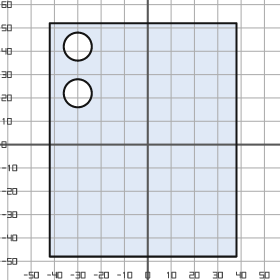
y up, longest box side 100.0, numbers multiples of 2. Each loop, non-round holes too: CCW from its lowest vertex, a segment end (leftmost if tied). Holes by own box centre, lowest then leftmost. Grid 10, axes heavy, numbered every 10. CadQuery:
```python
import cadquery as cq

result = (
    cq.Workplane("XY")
    .moveTo(-42.0, -48.0)
    .lineTo(38.0, -48.0)
    .lineTo(38.0, 52.0)
    .lineTo(-42.0, 52.0)
    .close()
    .moveTo(-30.0, 22.0)
    .circle(6.0)
    .moveTo(-30.0, 42.0)
    .circle(6.0)
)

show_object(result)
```